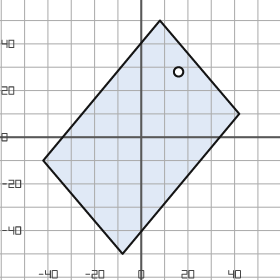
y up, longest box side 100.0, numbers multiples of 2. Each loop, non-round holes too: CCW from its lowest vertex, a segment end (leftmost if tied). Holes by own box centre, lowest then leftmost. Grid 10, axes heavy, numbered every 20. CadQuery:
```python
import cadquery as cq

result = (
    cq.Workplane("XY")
    .moveTo(-8.0, -50.0)
    .lineTo(42.0, 10.0)
    .lineTo(8.0, 50.0)
    .lineTo(-42.0, -10.0)
    .close()
    .moveTo(16.0, 28.0)
    .circle(2.0)
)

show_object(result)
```